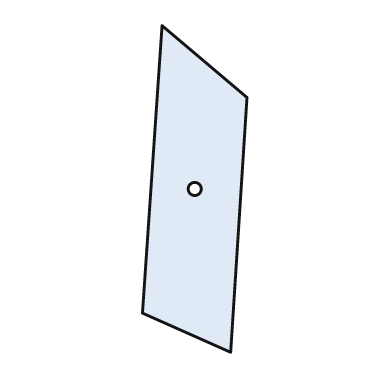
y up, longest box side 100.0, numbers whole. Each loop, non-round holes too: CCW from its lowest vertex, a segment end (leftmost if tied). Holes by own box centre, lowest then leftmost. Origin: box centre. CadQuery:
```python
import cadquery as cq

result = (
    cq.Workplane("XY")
    .moveTo(11.0, -50.0)
    .lineTo(16.0, 28.0)
    .lineTo(-10.0, 50.0)
    .lineTo(-16.0, -38.0)
    .close()
    .moveTo(0.0, 0.0)
    .circle(2.0)
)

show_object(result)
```